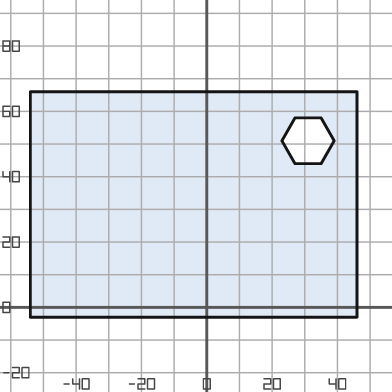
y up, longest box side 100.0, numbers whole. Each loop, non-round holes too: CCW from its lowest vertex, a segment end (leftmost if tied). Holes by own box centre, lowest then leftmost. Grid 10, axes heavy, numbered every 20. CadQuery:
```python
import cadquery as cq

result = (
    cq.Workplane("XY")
    .moveTo(-54.0, -3.0)
    .lineTo(46.0, -3.0)
    .lineTo(46.0, 66.0)
    .lineTo(-54.0, 66.0)
    .close()
    .moveTo(27.0, 44.0)
    .lineTo(35.0, 44.0)
    .lineTo(39.0, 51.0)
    .lineTo(35.0, 58.0)
    .lineTo(27.0, 58.0)
    .lineTo(23.0, 51.0)
    .close()
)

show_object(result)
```